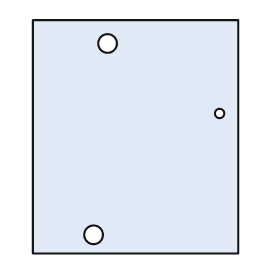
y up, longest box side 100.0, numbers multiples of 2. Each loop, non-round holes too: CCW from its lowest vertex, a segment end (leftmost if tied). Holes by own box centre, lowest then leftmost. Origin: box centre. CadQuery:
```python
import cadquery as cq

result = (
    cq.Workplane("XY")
    .moveTo(-44.0, -50.0)
    .lineTo(44.0, -50.0)
    .lineTo(44.0, 50.0)
    .lineTo(-44.0, 50.0)
    .close()
    .moveTo(-18.0, -42.0)
    .circle(4.0)
    .moveTo(36.0, 10.0)
    .circle(2.0)
    .moveTo(-12.0, 40.0)
    .circle(4.0)
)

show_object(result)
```